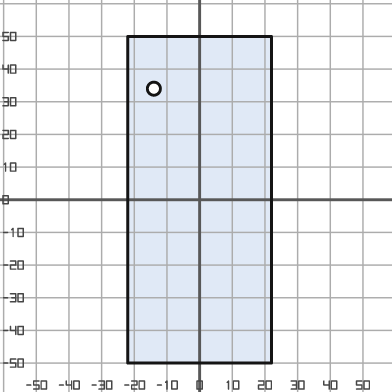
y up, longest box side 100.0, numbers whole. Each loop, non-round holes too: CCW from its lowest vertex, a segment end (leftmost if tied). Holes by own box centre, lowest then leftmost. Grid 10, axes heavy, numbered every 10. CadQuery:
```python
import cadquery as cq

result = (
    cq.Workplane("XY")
    .moveTo(-22.0, -50.0)
    .lineTo(22.0, -50.0)
    .lineTo(22.0, 50.0)
    .lineTo(-22.0, 50.0)
    .close()
    .moveTo(-14.0, 34.0)
    .circle(2.0)
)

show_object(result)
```